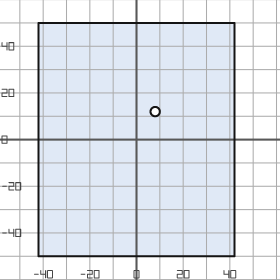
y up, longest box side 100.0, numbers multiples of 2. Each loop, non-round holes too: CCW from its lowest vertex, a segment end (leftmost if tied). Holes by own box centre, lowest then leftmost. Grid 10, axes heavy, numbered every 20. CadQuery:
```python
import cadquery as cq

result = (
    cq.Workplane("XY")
    .moveTo(-42.0, -50.0)
    .lineTo(42.0, -50.0)
    .lineTo(42.0, 50.0)
    .lineTo(-42.0, 50.0)
    .close()
    .moveTo(8.0, 12.0)
    .circle(2.0)
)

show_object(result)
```